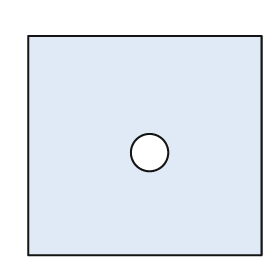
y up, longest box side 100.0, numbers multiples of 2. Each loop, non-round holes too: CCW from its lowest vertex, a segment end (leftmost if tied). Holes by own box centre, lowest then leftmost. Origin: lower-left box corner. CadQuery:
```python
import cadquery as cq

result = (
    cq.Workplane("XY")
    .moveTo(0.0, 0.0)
    .lineTo(100.0, 0.0)
    .lineTo(100.0, 94.0)
    .lineTo(0.0, 94.0)
    .close()
    .moveTo(52.0, 44.0)
    .circle(8.0)
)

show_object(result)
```